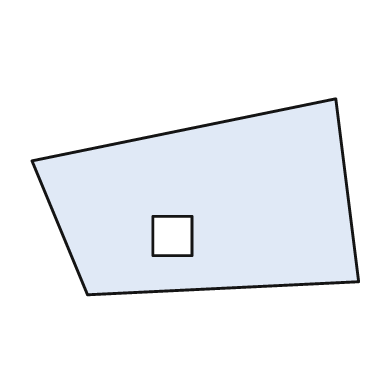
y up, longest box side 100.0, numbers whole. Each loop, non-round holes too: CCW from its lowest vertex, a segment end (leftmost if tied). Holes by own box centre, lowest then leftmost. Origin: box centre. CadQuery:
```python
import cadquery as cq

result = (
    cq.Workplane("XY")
    .moveTo(-33.0, -30.0)
    .lineTo(50.0, -26.0)
    .lineTo(43.0, 30.0)
    .lineTo(-50.0, 11.0)
    .close()
    .moveTo(-13.0, -18.0)
    .lineTo(-1.0, -18.0)
    .lineTo(-1.0, -6.0)
    .lineTo(-13.0, -6.0)
    .close()
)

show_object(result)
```